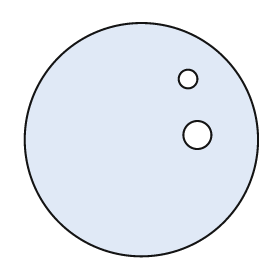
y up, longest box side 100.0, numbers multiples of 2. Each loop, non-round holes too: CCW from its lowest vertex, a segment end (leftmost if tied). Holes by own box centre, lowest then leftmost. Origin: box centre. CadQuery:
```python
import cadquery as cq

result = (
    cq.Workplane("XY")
    .moveTo(0.0, 0.0)
    .circle(50.0)
    .moveTo(24.0, 2.0)
    .circle(6.0)
    .moveTo(20.0, 26.0)
    .circle(4.0)
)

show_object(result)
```